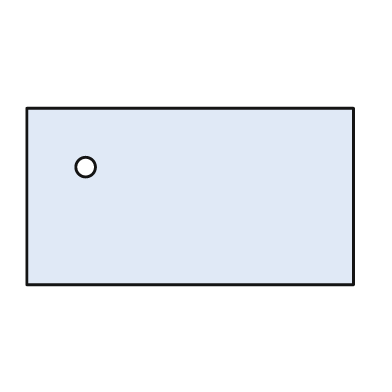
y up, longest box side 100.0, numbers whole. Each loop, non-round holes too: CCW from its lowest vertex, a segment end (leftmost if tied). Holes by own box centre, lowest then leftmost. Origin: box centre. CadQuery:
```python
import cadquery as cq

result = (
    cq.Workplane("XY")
    .moveTo(-50.0, -27.0)
    .lineTo(50.0, -27.0)
    .lineTo(50.0, 27.0)
    .lineTo(-50.0, 27.0)
    .close()
    .moveTo(-32.0, 9.0)
    .circle(3.0)
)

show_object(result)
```